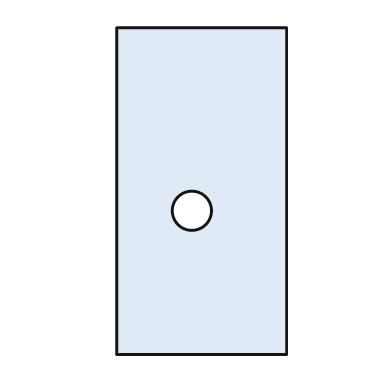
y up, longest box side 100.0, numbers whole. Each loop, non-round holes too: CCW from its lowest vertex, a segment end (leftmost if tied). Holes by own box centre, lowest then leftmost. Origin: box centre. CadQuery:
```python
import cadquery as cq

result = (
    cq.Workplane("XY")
    .moveTo(-26.0, -50.0)
    .lineTo(26.0, -50.0)
    .lineTo(26.0, 50.0)
    .lineTo(-26.0, 50.0)
    .close()
    .moveTo(-3.0, -6.0)
    .circle(6.0)
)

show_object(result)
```